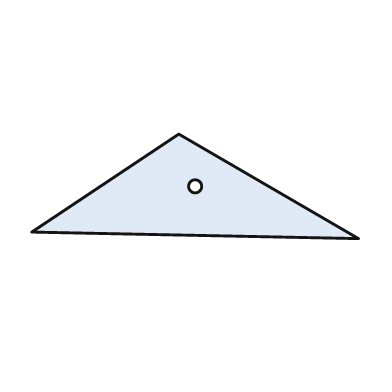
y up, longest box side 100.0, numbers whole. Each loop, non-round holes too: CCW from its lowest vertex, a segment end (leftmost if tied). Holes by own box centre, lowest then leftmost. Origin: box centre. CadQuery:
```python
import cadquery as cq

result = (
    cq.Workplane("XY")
    .moveTo(50.0, -16.0)
    .lineTo(-5.0, 16.0)
    .lineTo(-50.0, -14.0)
    .close()
    .moveTo(0.0, 0.0)
    .circle(2.0)
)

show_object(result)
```